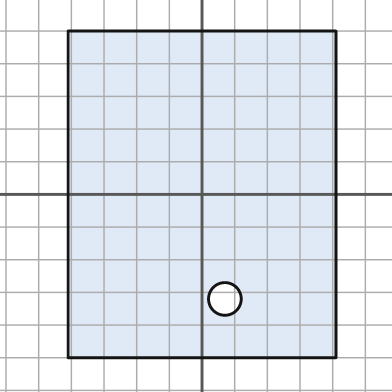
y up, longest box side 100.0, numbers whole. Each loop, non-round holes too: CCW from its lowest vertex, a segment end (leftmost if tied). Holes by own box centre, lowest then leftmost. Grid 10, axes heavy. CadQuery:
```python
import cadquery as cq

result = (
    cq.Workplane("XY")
    .moveTo(-41.0, -50.0)
    .lineTo(41.0, -50.0)
    .lineTo(41.0, 50.0)
    .lineTo(-41.0, 50.0)
    .close()
    .moveTo(7.0, -32.0)
    .circle(5.0)
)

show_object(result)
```